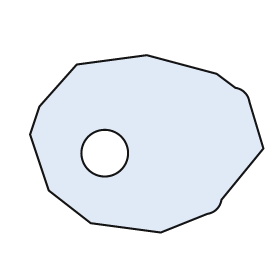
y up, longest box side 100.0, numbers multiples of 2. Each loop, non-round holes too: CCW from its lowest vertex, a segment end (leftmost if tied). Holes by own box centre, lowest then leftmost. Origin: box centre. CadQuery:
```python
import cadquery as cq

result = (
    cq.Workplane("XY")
    .moveTo(6.0, -38.0)
    .lineTo(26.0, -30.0)
    .threePointArc((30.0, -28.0), (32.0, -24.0))
    .lineTo(50.0, -2.0)
    .lineTo(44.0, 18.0)
    .threePointArc((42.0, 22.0), (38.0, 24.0))
    .lineTo(30.0, 30.0)
    .lineTo(0.0, 38.0)
    .lineTo(-30.0, 34.0)
    .lineTo(-46.0, 16.0)
    .lineTo(-50.0, 4.0)
    .lineTo(-42.0, -20.0)
    .lineTo(-24.0, -34.0)
    .close()
    .moveTo(-18.0, -4.0)
    .circle(10.0)
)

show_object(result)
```